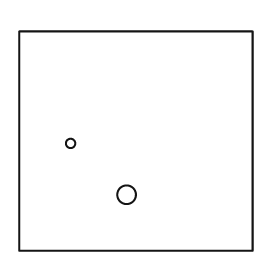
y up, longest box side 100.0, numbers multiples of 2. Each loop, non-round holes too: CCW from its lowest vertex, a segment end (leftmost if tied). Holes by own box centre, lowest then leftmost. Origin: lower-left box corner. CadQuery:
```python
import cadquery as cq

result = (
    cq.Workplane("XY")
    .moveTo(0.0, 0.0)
    .lineTo(100.0, 0.0)
    .lineTo(100.0, 94.0)
    .lineTo(0.0, 94.0)
    .close()
    .moveTo(46.0, 24.0)
    .circle(4.0)
    .moveTo(22.0, 46.0)
    .circle(2.0)
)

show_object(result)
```